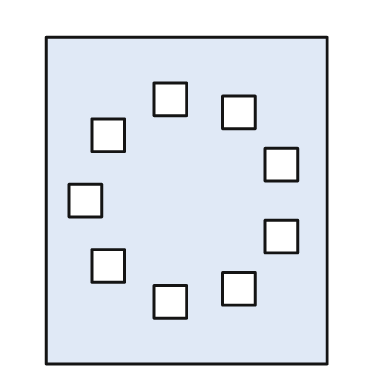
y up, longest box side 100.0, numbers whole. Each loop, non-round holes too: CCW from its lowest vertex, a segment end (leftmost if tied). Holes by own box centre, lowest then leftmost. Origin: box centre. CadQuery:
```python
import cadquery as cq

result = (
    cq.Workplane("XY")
    .moveTo(-43.0, -50.0)
    .lineTo(43.0, -50.0)
    .lineTo(43.0, 50.0)
    .lineTo(-43.0, 50.0)
    .close()
    .moveTo(-10.0, -36.0)
    .lineTo(0.0, -36.0)
    .lineTo(0.0, -26.0)
    .lineTo(-10.0, -26.0)
    .close()
    .moveTo(11.0, -32.0)
    .lineTo(21.0, -32.0)
    .lineTo(21.0, -22.0)
    .lineTo(11.0, -22.0)
    .close()
    .moveTo(-29.0, -25.0)
    .lineTo(-19.0, -25.0)
    .lineTo(-19.0, -15.0)
    .lineTo(-29.0, -15.0)
    .close()
    .moveTo(24.0, -16.0)
    .lineTo(34.0, -16.0)
    .lineTo(34.0, -6.0)
    .lineTo(24.0, -6.0)
    .close()
    .moveTo(-36.0, -5.0)
    .lineTo(-26.0, -5.0)
    .lineTo(-26.0, 5.0)
    .lineTo(-36.0, 5.0)
    .close()
    .moveTo(24.0, 6.0)
    .lineTo(34.0, 6.0)
    .lineTo(34.0, 16.0)
    .lineTo(24.0, 16.0)
    .close()
    .moveTo(-29.0, 15.0)
    .lineTo(-19.0, 15.0)
    .lineTo(-19.0, 25.0)
    .lineTo(-29.0, 25.0)
    .close()
    .moveTo(11.0, 22.0)
    .lineTo(21.0, 22.0)
    .lineTo(21.0, 32.0)
    .lineTo(11.0, 32.0)
    .close()
    .moveTo(-10.0, 26.0)
    .lineTo(0.0, 26.0)
    .lineTo(0.0, 36.0)
    .lineTo(-10.0, 36.0)
    .close()
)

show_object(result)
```